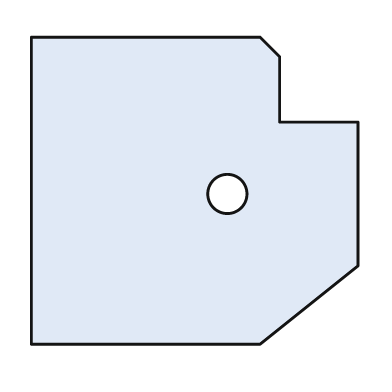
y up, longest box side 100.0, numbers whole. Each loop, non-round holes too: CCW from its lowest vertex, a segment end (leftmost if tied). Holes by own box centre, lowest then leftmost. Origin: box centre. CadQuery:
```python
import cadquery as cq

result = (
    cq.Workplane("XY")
    .moveTo(-50.0, -47.0)
    .lineTo(20.0, -47.0)
    .lineTo(50.0, -23.0)
    .lineTo(50.0, 21.0)
    .lineTo(26.0, 21.0)
    .lineTo(26.0, 41.0)
    .lineTo(20.0, 47.0)
    .lineTo(-50.0, 47.0)
    .close()
    .moveTo(10.0, -1.0)
    .circle(6.0)
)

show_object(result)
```